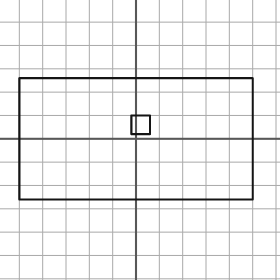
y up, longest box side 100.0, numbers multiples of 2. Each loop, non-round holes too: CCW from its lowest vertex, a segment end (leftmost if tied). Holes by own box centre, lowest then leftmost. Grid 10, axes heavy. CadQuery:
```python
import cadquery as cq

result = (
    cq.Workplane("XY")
    .moveTo(-50.0, -26.0)
    .lineTo(50.0, -26.0)
    .lineTo(50.0, 26.0)
    .lineTo(-50.0, 26.0)
    .close()
    .moveTo(-2.0, 2.0)
    .lineTo(6.0, 2.0)
    .lineTo(6.0, 10.0)
    .lineTo(-2.0, 10.0)
    .close()
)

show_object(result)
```